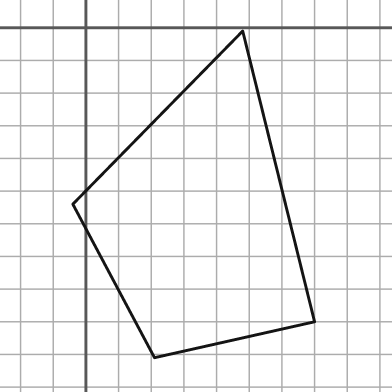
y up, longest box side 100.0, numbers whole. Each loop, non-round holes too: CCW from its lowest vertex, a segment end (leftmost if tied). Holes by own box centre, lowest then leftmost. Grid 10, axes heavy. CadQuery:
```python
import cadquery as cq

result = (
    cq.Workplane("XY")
    .moveTo(21.0, -101.0)
    .lineTo(70.0, -90.0)
    .lineTo(48.0, -1.0)
    .lineTo(-4.0, -54.0)
    .close()
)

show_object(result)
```